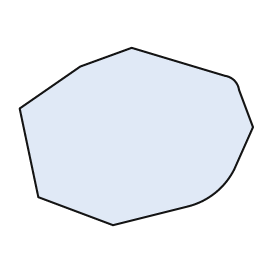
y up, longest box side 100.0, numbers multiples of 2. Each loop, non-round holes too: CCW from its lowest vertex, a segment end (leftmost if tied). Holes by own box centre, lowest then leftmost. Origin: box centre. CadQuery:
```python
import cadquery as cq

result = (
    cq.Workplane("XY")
    .moveTo(-10.0, -38.0)
    .lineTo(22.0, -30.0)
    .threePointArc((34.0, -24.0), (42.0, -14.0))
    .lineTo(50.0, 4.0)
    .lineTo(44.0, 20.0)
    .threePointArc((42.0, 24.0), (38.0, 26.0))
    .lineTo(-2.0, 38.0)
    .lineTo(-24.0, 30.0)
    .lineTo(-50.0, 12.0)
    .lineTo(-42.0, -26.0)
    .close()
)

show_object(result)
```